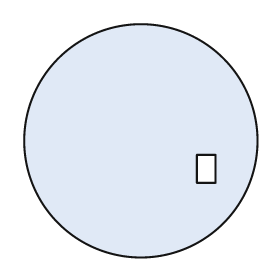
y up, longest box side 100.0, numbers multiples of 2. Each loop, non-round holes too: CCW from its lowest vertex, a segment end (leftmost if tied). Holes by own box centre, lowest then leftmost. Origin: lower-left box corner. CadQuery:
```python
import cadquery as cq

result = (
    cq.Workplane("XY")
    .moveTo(50.0, 50.0)
    .circle(50.0)
    .moveTo(74.0, 32.0)
    .lineTo(82.0, 32.0)
    .lineTo(82.0, 44.0)
    .lineTo(74.0, 44.0)
    .close()
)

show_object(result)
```